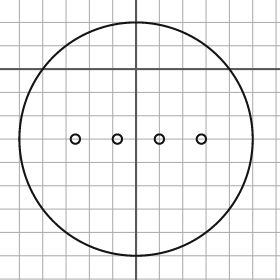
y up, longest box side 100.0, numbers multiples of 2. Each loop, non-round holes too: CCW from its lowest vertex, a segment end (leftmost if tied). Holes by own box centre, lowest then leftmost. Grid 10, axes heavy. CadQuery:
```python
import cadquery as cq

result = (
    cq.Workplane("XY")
    .moveTo(0.0, -30.0)
    .circle(50.0)
    .moveTo(-26.0, -30.0)
    .circle(2.0)
    .moveTo(-8.0, -30.0)
    .circle(2.0)
    .moveTo(10.0, -30.0)
    .circle(2.0)
    .moveTo(28.0, -30.0)
    .circle(2.0)
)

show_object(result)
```